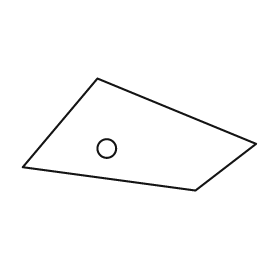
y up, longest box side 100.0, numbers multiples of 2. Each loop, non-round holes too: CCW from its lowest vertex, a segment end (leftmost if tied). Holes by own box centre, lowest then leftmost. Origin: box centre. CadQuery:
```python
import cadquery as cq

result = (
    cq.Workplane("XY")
    .moveTo(24.0, -24.0)
    .lineTo(50.0, -4.0)
    .lineTo(-18.0, 24.0)
    .lineTo(-50.0, -14.0)
    .close()
    .moveTo(-14.0, -6.0)
    .circle(4.0)
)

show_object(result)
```